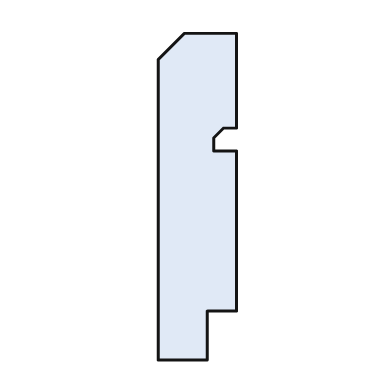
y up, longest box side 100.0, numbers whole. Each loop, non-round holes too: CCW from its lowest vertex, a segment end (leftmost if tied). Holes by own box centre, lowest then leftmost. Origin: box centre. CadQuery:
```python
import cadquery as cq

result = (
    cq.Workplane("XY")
    .moveTo(-12.0, -50.0)
    .lineTo(3.0, -50.0)
    .lineTo(3.0, -35.0)
    .lineTo(12.0, -35.0)
    .lineTo(12.0, 14.0)
    .lineTo(5.0, 14.0)
    .lineTo(5.0, 18.0)
    .lineTo(8.0, 21.0)
    .lineTo(12.0, 21.0)
    .lineTo(12.0, 50.0)
    .lineTo(-4.0, 50.0)
    .lineTo(-12.0, 42.0)
    .close()
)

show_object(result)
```